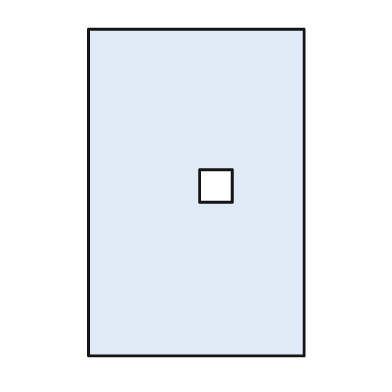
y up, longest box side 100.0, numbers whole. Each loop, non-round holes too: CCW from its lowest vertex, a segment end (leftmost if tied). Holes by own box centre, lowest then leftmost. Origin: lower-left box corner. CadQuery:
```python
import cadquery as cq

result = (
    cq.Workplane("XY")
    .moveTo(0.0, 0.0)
    .lineTo(66.0, 0.0)
    .lineTo(66.0, 100.0)
    .lineTo(0.0, 100.0)
    .close()
    .moveTo(34.0, 47.0)
    .lineTo(44.0, 47.0)
    .lineTo(44.0, 57.0)
    .lineTo(34.0, 57.0)
    .close()
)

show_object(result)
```